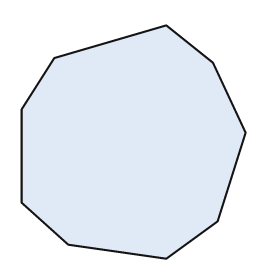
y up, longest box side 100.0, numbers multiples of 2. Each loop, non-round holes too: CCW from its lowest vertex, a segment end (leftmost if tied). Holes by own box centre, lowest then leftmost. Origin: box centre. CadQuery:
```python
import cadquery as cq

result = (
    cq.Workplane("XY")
    .moveTo(14.0, -50.0)
    .lineTo(36.0, -34.0)
    .lineTo(48.0, 4.0)
    .lineTo(34.0, 34.0)
    .lineTo(14.0, 50.0)
    .lineTo(-34.0, 36.0)
    .lineTo(-48.0, 14.0)
    .lineTo(-48.0, -26.0)
    .lineTo(-28.0, -44.0)
    .close()
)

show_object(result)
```